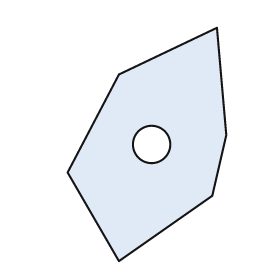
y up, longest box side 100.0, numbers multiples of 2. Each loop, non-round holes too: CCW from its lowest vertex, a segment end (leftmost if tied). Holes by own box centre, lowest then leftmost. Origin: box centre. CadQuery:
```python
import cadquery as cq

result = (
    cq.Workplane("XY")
    .moveTo(-12.0, -50.0)
    .lineTo(28.0, -22.0)
    .lineTo(34.0, 4.0)
    .lineTo(30.0, 50.0)
    .lineTo(-12.0, 30.0)
    .lineTo(-34.0, -12.0)
    .close()
    .moveTo(2.0, 0.0)
    .circle(8.0)
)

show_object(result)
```